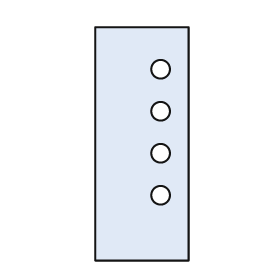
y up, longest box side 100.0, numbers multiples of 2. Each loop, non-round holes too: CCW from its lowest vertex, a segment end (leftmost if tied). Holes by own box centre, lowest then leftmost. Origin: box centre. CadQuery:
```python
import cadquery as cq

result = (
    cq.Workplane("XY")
    .moveTo(-20.0, -50.0)
    .lineTo(20.0, -50.0)
    .lineTo(20.0, 50.0)
    .lineTo(-20.0, 50.0)
    .close()
    .moveTo(8.0, -22.0)
    .circle(4.0)
    .moveTo(8.0, -4.0)
    .circle(4.0)
    .moveTo(8.0, 14.0)
    .circle(4.0)
    .moveTo(8.0, 32.0)
    .circle(4.0)
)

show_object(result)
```